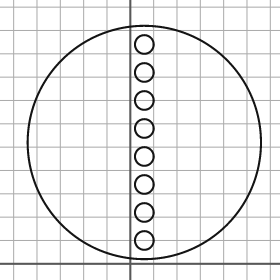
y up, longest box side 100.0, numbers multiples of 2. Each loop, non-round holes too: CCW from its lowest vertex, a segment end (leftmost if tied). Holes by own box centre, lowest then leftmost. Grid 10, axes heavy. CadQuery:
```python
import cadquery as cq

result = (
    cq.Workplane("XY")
    .moveTo(6.0, 52.0)
    .circle(50.0)
    .moveTo(6.0, 10.0)
    .circle(4.0)
    .moveTo(6.0, 22.0)
    .circle(4.0)
    .moveTo(6.0, 34.0)
    .circle(4.0)
    .moveTo(6.0, 46.0)
    .circle(4.0)
    .moveTo(6.0, 58.0)
    .circle(4.0)
    .moveTo(6.0, 70.0)
    .circle(4.0)
    .moveTo(6.0, 82.0)
    .circle(4.0)
    .moveTo(6.0, 94.0)
    .circle(4.0)
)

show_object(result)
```